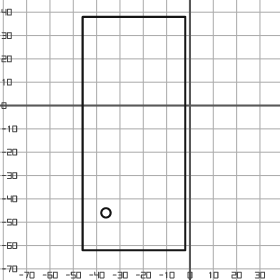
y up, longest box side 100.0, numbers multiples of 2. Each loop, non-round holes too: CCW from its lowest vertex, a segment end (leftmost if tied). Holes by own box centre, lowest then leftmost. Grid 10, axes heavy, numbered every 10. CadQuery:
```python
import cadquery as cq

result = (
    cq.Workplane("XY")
    .moveTo(-46.0, -62.0)
    .lineTo(-2.0, -62.0)
    .lineTo(-2.0, 38.0)
    .lineTo(-46.0, 38.0)
    .close()
    .moveTo(-36.0, -46.0)
    .circle(2.0)
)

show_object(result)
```